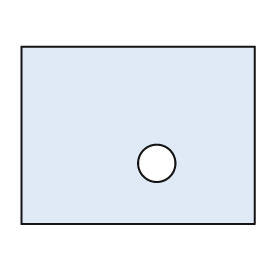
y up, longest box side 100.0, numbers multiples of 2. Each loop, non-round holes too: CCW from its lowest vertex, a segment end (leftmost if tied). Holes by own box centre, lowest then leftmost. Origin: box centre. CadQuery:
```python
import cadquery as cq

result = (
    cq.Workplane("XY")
    .moveTo(-50.0, -38.0)
    .lineTo(50.0, -38.0)
    .lineTo(50.0, 38.0)
    .lineTo(-50.0, 38.0)
    .close()
    .moveTo(8.0, -12.0)
    .circle(8.0)
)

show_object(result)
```